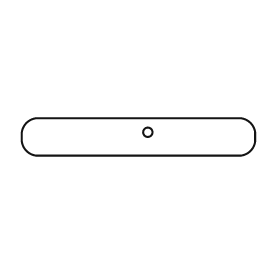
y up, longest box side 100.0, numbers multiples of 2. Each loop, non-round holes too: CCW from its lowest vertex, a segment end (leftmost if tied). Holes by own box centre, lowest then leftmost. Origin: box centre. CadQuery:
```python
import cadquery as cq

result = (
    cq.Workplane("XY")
    .moveTo(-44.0, -8.0)
    .lineTo(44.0, -8.0)
    .threePointArc((48.0, -6.0), (50.0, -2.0))
    .lineTo(50.0, 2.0)
    .threePointArc((48.0, 6.0), (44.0, 8.0))
    .lineTo(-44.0, 8.0)
    .threePointArc((-48.0, 6.0), (-50.0, 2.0))
    .lineTo(-50.0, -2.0)
    .threePointArc((-48.0, -6.0), (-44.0, -8.0))
    .close()
    .moveTo(4.0, 2.0)
    .circle(2.0)
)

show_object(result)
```